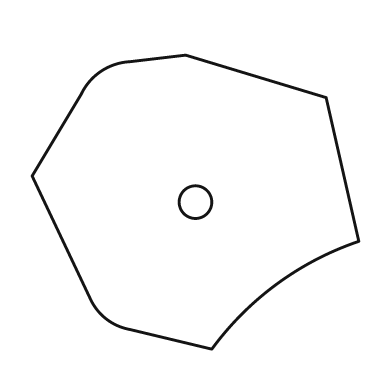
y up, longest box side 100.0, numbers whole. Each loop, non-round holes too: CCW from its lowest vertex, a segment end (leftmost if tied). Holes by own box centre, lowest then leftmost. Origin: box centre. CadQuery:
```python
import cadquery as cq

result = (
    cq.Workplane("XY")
    .moveTo(5.0, -45.0)
    .threePointArc((25.0, -25.0), (50.0, -12.0))
    .lineTo(40.0, 32.0)
    .lineTo(-3.0, 45.0)
    .lineTo(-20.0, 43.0)
    .threePointArc((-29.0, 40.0), (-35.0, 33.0))
    .lineTo(-50.0, 8.0)
    .lineTo(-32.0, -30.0)
    .threePointArc((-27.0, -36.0), (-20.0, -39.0))
    .close()
    .moveTo(0.0, 0.0)
    .circle(5.0)
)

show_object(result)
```